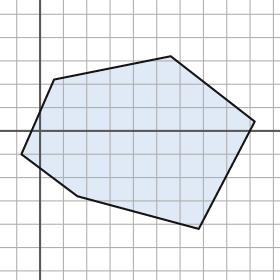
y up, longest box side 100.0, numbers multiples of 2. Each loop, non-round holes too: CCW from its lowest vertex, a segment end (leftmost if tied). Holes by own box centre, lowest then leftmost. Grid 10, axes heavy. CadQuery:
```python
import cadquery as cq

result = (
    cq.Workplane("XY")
    .moveTo(68.0, -42.0)
    .lineTo(92.0, 4.0)
    .lineTo(56.0, 32.0)
    .lineTo(6.0, 22.0)
    .lineTo(-8.0, -10.0)
    .lineTo(16.0, -28.0)
    .close()
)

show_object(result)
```